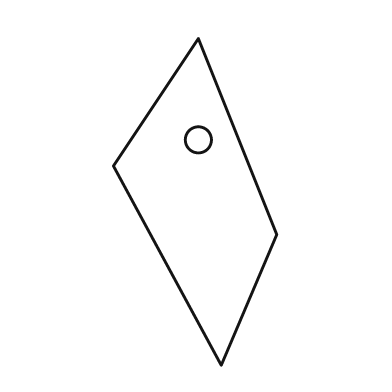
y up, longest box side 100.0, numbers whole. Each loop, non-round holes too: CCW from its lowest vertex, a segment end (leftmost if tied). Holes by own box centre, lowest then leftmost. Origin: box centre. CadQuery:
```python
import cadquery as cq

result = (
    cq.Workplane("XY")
    .moveTo(8.0, -50.0)
    .lineTo(25.0, -10.0)
    .lineTo(1.0, 50.0)
    .lineTo(-25.0, 11.0)
    .close()
    .moveTo(1.0, 19.0)
    .circle(4.0)
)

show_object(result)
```